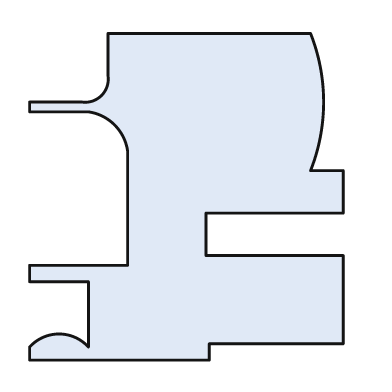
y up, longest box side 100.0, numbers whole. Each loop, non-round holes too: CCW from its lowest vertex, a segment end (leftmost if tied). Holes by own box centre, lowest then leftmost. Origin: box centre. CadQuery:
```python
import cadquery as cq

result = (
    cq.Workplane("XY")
    .moveTo(-48.0, -50.0)
    .lineTo(7.0, -50.0)
    .lineTo(7.0, -45.0)
    .lineTo(48.0, -45.0)
    .lineTo(48.0, -18.0)
    .lineTo(6.0, -18.0)
    .lineTo(6.0, -5.0)
    .lineTo(48.0, -5.0)
    .lineTo(48.0, 8.0)
    .lineTo(38.0, 8.0)
    .threePointArc((42.0, 29.0), (38.0, 50.0))
    .lineTo(-24.0, 50.0)
    .lineTo(-24.0, 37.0)
    .threePointArc((-26.0, 31.0), (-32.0, 29.0))
    .lineTo(-48.0, 29.0)
    .lineTo(-48.0, 26.0)
    .lineTo(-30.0, 26.0)
    .threePointArc((-22.0, 22.0), (-18.0, 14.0))
    .lineTo(-18.0, -21.0)
    .lineTo(-48.0, -21.0)
    .lineTo(-48.0, -26.0)
    .lineTo(-30.0, -26.0)
    .lineTo(-30.0, -46.0)
    .threePointArc((-39.0, -42.0), (-48.0, -46.0))
    .close()
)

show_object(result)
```